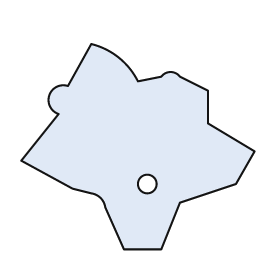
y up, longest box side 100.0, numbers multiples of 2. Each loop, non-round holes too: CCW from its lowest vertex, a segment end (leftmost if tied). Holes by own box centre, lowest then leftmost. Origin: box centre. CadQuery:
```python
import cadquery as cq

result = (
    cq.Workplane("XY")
    .moveTo(-6.0, -44.0)
    .lineTo(10.0, -44.0)
    .lineTo(18.0, -24.0)
    .lineTo(42.0, -16.0)
    .lineTo(50.0, -2.0)
    .lineTo(30.0, 10.0)
    .lineTo(30.0, 24.0)
    .lineTo(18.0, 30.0)
    .threePointArc((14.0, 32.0), (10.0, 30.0))
    .lineTo(0.0, 28.0)
    .threePointArc((-8.0, 38.0), (-20.0, 44.0))
    .lineTo(-30.0, 26.0)
    .threePointArc((-38.0, 22.0), (-34.0, 14.0))
    .lineTo(-50.0, -6.0)
    .lineTo(-28.0, -18.0)
    .lineTo(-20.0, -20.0)
    .threePointArc((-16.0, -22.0), (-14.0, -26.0))
    .close()
    .moveTo(4.0, -16.0)
    .circle(4.0)
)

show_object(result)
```